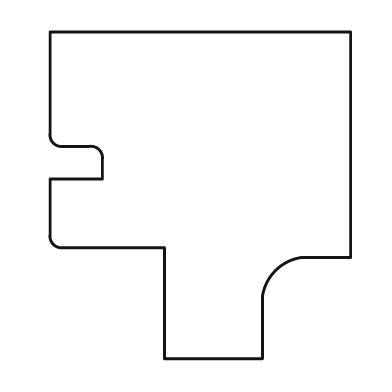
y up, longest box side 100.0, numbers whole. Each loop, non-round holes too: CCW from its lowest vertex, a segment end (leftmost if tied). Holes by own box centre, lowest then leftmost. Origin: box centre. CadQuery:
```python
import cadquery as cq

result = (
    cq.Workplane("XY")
    .moveTo(-11.0, -50.0)
    .lineTo(19.0, -50.0)
    .lineTo(19.0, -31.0)
    .threePointArc((23.0, -23.0), (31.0, -19.0))
    .lineTo(46.0, -19.0)
    .lineTo(46.0, 50.0)
    .lineTo(-46.0, 50.0)
    .lineTo(-46.0, 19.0)
    .threePointArc((-45.0, 16.0), (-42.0, 15.0))
    .lineTo(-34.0, 15.0)
    .threePointArc((-31.0, 14.0), (-30.0, 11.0))
    .lineTo(-30.0, 5.0)
    .lineTo(-46.0, 5.0)
    .lineTo(-46.0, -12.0)
    .threePointArc((-45.0, -15.0), (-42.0, -16.0))
    .lineTo(-11.0, -16.0)
    .close()
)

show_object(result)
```